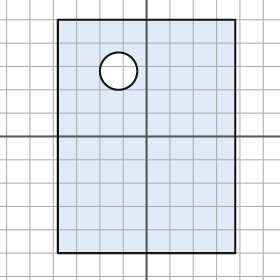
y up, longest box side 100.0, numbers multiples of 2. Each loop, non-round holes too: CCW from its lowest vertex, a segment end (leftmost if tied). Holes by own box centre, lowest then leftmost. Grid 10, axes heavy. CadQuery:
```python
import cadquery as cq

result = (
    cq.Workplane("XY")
    .moveTo(-38.0, -50.0)
    .lineTo(38.0, -50.0)
    .lineTo(38.0, 50.0)
    .lineTo(-38.0, 50.0)
    .close()
    .moveTo(-12.0, 28.0)
    .circle(8.0)
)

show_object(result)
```